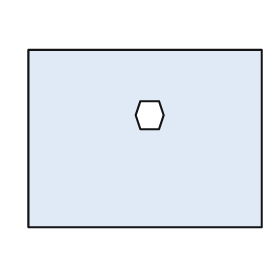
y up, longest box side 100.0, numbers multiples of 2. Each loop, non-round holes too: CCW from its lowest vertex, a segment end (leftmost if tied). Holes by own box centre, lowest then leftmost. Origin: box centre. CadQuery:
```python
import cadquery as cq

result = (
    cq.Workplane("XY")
    .moveTo(-50.0, -38.0)
    .lineTo(50.0, -38.0)
    .lineTo(50.0, 38.0)
    .lineTo(-50.0, 38.0)
    .close()
    .moveTo(-2.0, 4.0)
    .lineTo(6.0, 4.0)
    .lineTo(8.0, 10.0)
    .lineTo(6.0, 16.0)
    .lineTo(-2.0, 16.0)
    .lineTo(-4.0, 10.0)
    .close()
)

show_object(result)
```